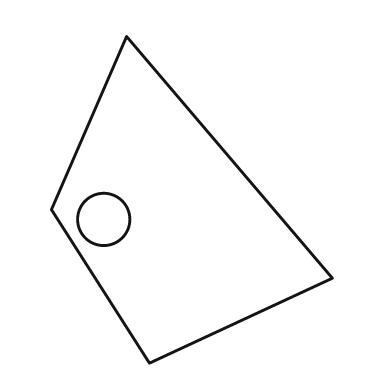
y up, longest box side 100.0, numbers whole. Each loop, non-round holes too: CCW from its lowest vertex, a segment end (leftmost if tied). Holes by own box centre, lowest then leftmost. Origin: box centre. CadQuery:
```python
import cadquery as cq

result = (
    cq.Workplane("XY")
    .moveTo(-13.0, -50.0)
    .lineTo(43.0, -24.0)
    .lineTo(-20.0, 50.0)
    .lineTo(-43.0, -3.0)
    .close()
    .moveTo(-27.0, -6.0)
    .circle(8.0)
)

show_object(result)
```